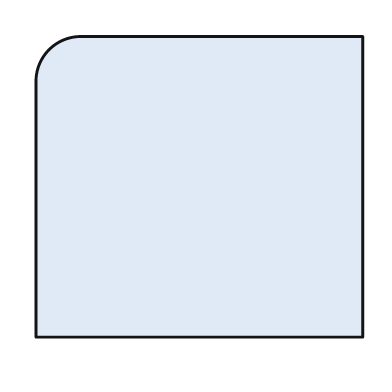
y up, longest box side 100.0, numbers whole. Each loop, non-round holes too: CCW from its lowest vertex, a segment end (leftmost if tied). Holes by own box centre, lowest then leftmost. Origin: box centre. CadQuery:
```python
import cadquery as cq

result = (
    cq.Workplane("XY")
    .moveTo(-50.0, -46.0)
    .lineTo(50.0, -46.0)
    .lineTo(50.0, 46.0)
    .lineTo(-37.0, 46.0)
    .threePointArc((-46.0, 42.0), (-50.0, 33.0))
    .close()
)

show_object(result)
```